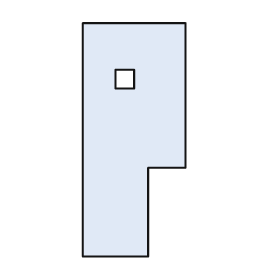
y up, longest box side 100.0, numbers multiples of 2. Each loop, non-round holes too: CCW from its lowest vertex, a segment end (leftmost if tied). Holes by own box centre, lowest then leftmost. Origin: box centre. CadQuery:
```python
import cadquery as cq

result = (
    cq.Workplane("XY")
    .moveTo(-22.0, -50.0)
    .lineTo(6.0, -50.0)
    .lineTo(6.0, -12.0)
    .lineTo(22.0, -12.0)
    .lineTo(22.0, 50.0)
    .lineTo(-22.0, 50.0)
    .close()
    .moveTo(-8.0, 22.0)
    .lineTo(0.0, 22.0)
    .lineTo(0.0, 30.0)
    .lineTo(-8.0, 30.0)
    .close()
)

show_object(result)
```